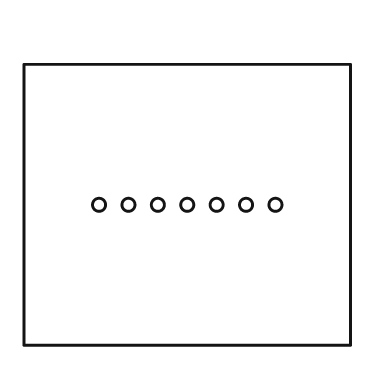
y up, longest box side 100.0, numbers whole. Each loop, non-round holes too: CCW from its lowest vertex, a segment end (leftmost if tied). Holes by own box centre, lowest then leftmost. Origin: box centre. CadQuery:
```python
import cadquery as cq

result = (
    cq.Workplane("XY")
    .moveTo(-50.0, -43.0)
    .lineTo(50.0, -43.0)
    .lineTo(50.0, 43.0)
    .lineTo(-50.0, 43.0)
    .close()
    .moveTo(-27.0, 0.0)
    .circle(2.0)
    .moveTo(-18.0, 0.0)
    .circle(2.0)
    .moveTo(-9.0, 0.0)
    .circle(2.0)
    .moveTo(0.0, 0.0)
    .circle(2.0)
    .moveTo(9.0, 0.0)
    .circle(2.0)
    .moveTo(18.0, 0.0)
    .circle(2.0)
    .moveTo(27.0, 0.0)
    .circle(2.0)
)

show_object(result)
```